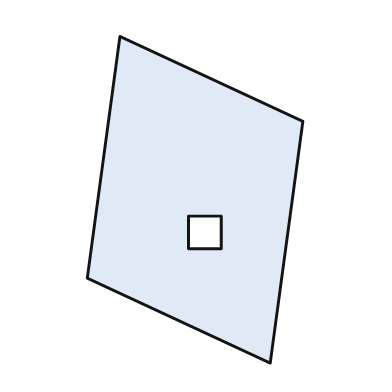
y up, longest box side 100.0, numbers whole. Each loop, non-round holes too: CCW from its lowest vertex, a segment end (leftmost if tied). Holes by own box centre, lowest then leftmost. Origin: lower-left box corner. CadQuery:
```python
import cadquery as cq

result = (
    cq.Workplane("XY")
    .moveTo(56.0, 0.0)
    .lineTo(66.0, 74.0)
    .lineTo(10.0, 100.0)
    .lineTo(0.0, 26.0)
    .close()
    .moveTo(31.0, 35.0)
    .lineTo(41.0, 35.0)
    .lineTo(41.0, 45.0)
    .lineTo(31.0, 45.0)
    .close()
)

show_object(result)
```